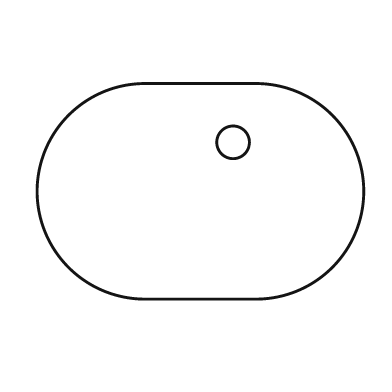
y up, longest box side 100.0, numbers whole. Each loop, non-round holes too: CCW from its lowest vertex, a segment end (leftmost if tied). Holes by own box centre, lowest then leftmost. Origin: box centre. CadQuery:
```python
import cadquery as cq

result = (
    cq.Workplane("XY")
    .moveTo(-17.0, -33.0)
    .lineTo(17.0, -33.0)
    .threePointArc((50.0, 0.0), (17.0, 33.0))
    .lineTo(-17.0, 33.0)
    .threePointArc((-50.0, 0.0), (-17.0, -33.0))
    .close()
    .moveTo(10.0, 15.0)
    .circle(5.0)
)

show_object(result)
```